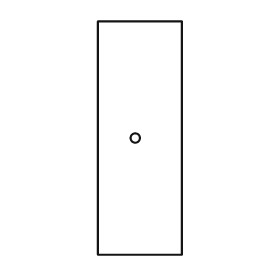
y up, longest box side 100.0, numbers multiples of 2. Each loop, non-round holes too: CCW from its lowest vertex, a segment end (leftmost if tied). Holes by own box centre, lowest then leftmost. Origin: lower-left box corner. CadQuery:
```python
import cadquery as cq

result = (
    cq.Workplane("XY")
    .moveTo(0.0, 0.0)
    .lineTo(36.0, 0.0)
    .lineTo(36.0, 100.0)
    .lineTo(0.0, 100.0)
    .close()
    .moveTo(16.0, 50.0)
    .circle(2.0)
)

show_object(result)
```